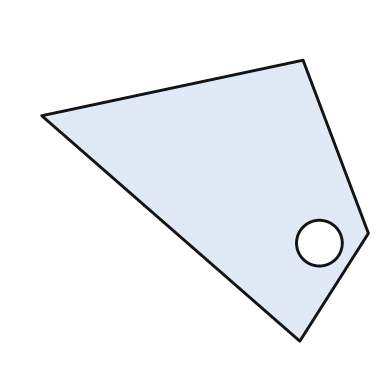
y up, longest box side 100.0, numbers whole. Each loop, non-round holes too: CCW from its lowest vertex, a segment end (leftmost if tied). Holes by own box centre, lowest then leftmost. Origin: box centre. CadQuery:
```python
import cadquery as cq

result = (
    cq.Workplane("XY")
    .moveTo(29.0, -43.0)
    .lineTo(50.0, -10.0)
    .lineTo(30.0, 43.0)
    .lineTo(-50.0, 26.0)
    .close()
    .moveTo(35.0, -13.0)
    .circle(7.0)
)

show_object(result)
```